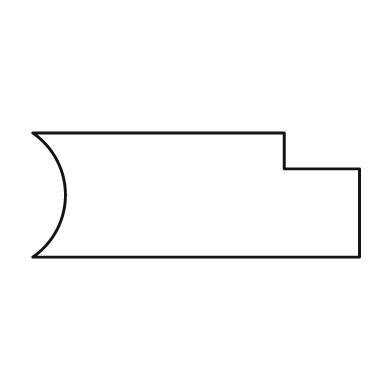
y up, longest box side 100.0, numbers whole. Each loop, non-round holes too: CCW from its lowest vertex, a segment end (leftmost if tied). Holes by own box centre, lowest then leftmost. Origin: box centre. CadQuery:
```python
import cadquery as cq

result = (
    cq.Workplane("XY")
    .moveTo(-50.0, -19.0)
    .lineTo(50.0, -19.0)
    .lineTo(50.0, 8.0)
    .lineTo(27.0, 8.0)
    .lineTo(27.0, 19.0)
    .lineTo(-50.0, 19.0)
    .threePointArc((-40.0, 0.0), (-50.0, -19.0))
    .close()
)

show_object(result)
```